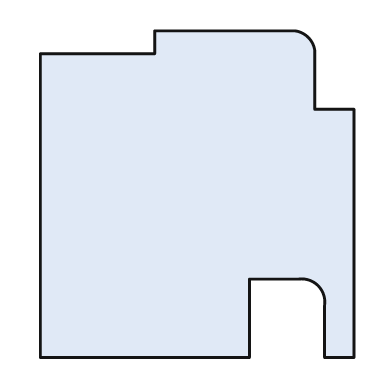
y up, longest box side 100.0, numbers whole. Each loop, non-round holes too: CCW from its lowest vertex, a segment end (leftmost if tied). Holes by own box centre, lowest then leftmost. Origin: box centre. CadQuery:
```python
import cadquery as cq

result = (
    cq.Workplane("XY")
    .moveTo(-48.0, -50.0)
    .lineTo(16.0, -50.0)
    .lineTo(16.0, -26.0)
    .lineTo(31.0, -26.0)
    .threePointArc((37.0, -28.0), (39.0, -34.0))
    .lineTo(39.0, -50.0)
    .lineTo(48.0, -50.0)
    .lineTo(48.0, 26.0)
    .lineTo(36.0, 26.0)
    .lineTo(36.0, 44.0)
    .threePointArc((34.0, 48.0), (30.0, 50.0))
    .lineTo(-13.0, 50.0)
    .lineTo(-13.0, 43.0)
    .lineTo(-48.0, 43.0)
    .close()
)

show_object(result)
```